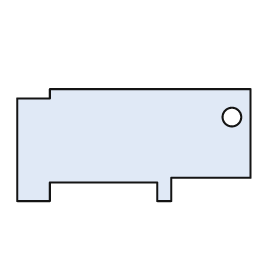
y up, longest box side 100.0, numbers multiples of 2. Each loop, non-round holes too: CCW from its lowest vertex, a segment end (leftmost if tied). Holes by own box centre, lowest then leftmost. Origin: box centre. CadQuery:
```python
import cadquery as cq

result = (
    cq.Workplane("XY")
    .moveTo(-50.0, -24.0)
    .lineTo(-36.0, -24.0)
    .lineTo(-36.0, -16.0)
    .lineTo(10.0, -16.0)
    .lineTo(10.0, -24.0)
    .lineTo(16.0, -24.0)
    .lineTo(16.0, -14.0)
    .lineTo(50.0, -14.0)
    .lineTo(50.0, 24.0)
    .lineTo(-36.0, 24.0)
    .lineTo(-36.0, 20.0)
    .lineTo(-50.0, 20.0)
    .close()
    .moveTo(42.0, 12.0)
    .circle(4.0)
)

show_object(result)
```